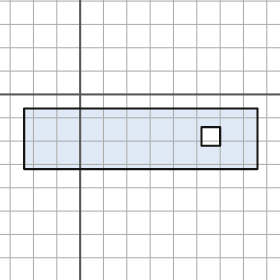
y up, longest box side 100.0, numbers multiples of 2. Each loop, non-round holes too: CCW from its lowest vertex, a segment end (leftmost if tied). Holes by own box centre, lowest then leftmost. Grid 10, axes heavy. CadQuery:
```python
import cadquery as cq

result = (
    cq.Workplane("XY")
    .moveTo(-24.0, -32.0)
    .lineTo(76.0, -32.0)
    .lineTo(76.0, -6.0)
    .lineTo(-24.0, -6.0)
    .close()
    .moveTo(52.0, -22.0)
    .lineTo(60.0, -22.0)
    .lineTo(60.0, -14.0)
    .lineTo(52.0, -14.0)
    .close()
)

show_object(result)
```